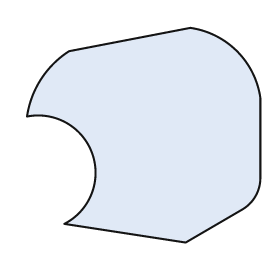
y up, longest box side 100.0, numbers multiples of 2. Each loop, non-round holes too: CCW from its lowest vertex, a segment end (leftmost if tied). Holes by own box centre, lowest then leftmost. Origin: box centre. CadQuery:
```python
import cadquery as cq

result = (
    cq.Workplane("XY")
    .moveTo(18.0, -46.0)
    .lineTo(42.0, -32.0)
    .threePointArc((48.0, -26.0), (50.0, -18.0))
    .lineTo(50.0, 16.0)
    .threePointArc((40.0, 36.0), (20.0, 46.0))
    .lineTo(-32.0, 36.0)
    .threePointArc((-44.0, 24.0), (-50.0, 8.0))
    .threePointArc((-22.0, -8.0), (-34.0, -38.0))
    .close()
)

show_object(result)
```